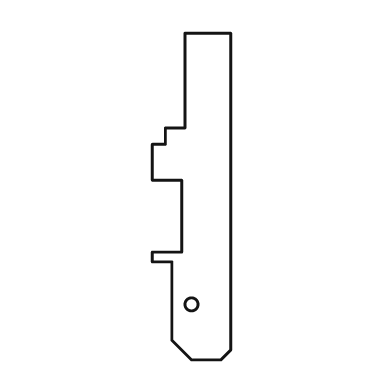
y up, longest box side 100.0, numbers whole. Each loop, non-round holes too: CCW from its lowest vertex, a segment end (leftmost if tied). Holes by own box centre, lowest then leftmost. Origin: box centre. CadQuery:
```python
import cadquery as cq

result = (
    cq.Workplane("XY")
    .moveTo(0.0, -50.0)
    .lineTo(9.0, -50.0)
    .lineTo(12.0, -47.0)
    .lineTo(12.0, 50.0)
    .lineTo(-2.0, 50.0)
    .lineTo(-2.0, 21.0)
    .lineTo(-8.0, 21.0)
    .lineTo(-8.0, 16.0)
    .lineTo(-12.0, 16.0)
    .lineTo(-12.0, 5.0)
    .lineTo(-3.0, 5.0)
    .lineTo(-3.0, -17.0)
    .lineTo(-12.0, -17.0)
    .lineTo(-12.0, -20.0)
    .lineTo(-6.0, -20.0)
    .lineTo(-6.0, -44.0)
    .close()
    .moveTo(0.0, -33.0)
    .circle(2.0)
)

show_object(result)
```